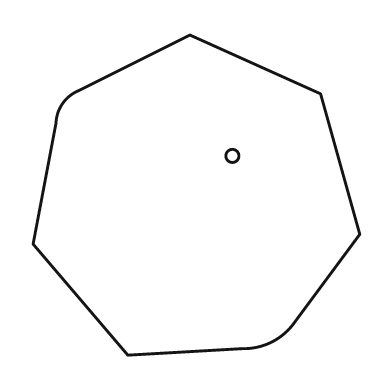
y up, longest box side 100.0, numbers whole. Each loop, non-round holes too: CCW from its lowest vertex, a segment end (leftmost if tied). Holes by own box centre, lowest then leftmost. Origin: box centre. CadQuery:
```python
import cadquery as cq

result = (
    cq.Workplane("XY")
    .moveTo(-21.0, -49.0)
    .lineTo(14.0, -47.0)
    .threePointArc((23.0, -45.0), (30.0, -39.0))
    .lineTo(50.0, -12.0)
    .lineTo(38.0, 31.0)
    .lineTo(-2.0, 49.0)
    .lineTo(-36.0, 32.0)
    .threePointArc((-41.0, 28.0), (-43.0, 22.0))
    .lineTo(-50.0, -15.0)
    .close()
    .moveTo(11.0, 12.0)
    .circle(2.0)
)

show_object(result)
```